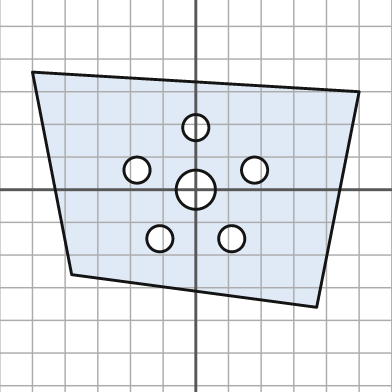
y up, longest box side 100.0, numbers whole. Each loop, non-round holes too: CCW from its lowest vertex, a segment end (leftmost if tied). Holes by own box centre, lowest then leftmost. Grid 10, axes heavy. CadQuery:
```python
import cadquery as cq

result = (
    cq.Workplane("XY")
    .moveTo(37.0, -36.0)
    .lineTo(50.0, 30.0)
    .lineTo(-50.0, 36.0)
    .lineTo(-38.0, -26.0)
    .close()
    .moveTo(-11.0, -15.0)
    .circle(4.0)
    .moveTo(11.0, -15.0)
    .circle(4.0)
    .moveTo(0.0, 0.0)
    .circle(6.0)
    .moveTo(-18.0, 6.0)
    .circle(4.0)
    .moveTo(18.0, 6.0)
    .circle(4.0)
    .moveTo(0.0, 19.0)
    .circle(4.0)
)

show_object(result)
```